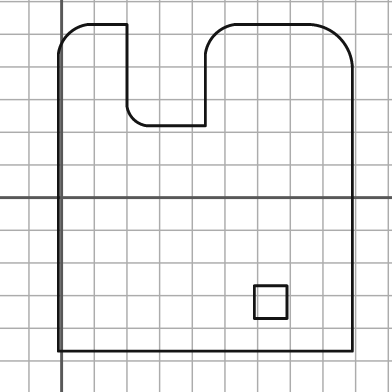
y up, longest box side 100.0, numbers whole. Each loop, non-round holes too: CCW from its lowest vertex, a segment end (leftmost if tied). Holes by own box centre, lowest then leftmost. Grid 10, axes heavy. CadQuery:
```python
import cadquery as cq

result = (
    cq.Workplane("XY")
    .moveTo(-1.0, -47.0)
    .lineTo(89.0, -47.0)
    .lineTo(89.0, 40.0)
    .threePointArc((85.0, 49.0), (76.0, 53.0))
    .lineTo(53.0, 53.0)
    .threePointArc((47.0, 50.0), (44.0, 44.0))
    .lineTo(44.0, 22.0)
    .lineTo(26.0, 22.0)
    .threePointArc((22.0, 24.0), (20.0, 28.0))
    .lineTo(20.0, 53.0)
    .lineTo(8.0, 53.0)
    .threePointArc((2.0, 50.0), (-1.0, 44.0))
    .close()
    .moveTo(59.0, -37.0)
    .lineTo(69.0, -37.0)
    .lineTo(69.0, -27.0)
    .lineTo(59.0, -27.0)
    .close()
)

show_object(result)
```